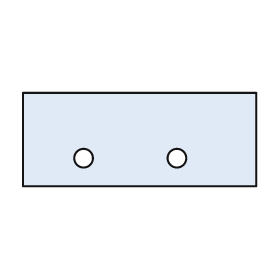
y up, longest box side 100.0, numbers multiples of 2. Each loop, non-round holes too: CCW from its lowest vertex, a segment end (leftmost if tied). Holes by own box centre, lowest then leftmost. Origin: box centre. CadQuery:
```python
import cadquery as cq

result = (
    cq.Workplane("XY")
    .moveTo(-50.0, -20.0)
    .lineTo(50.0, -20.0)
    .lineTo(50.0, 20.0)
    .lineTo(-50.0, 20.0)
    .close()
    .moveTo(-24.0, -8.0)
    .circle(4.0)
    .moveTo(16.0, -8.0)
    .circle(4.0)
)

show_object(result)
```